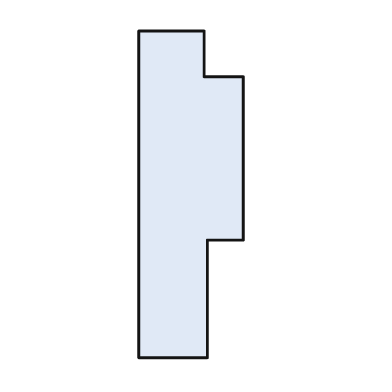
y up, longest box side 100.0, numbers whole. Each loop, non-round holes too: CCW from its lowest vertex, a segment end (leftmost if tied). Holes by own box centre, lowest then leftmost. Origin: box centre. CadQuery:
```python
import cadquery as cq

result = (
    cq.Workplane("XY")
    .moveTo(-16.0, -50.0)
    .lineTo(5.0, -50.0)
    .lineTo(5.0, -14.0)
    .lineTo(16.0, -14.0)
    .lineTo(16.0, 36.0)
    .lineTo(4.0, 36.0)
    .lineTo(4.0, 50.0)
    .lineTo(-16.0, 50.0)
    .close()
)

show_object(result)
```